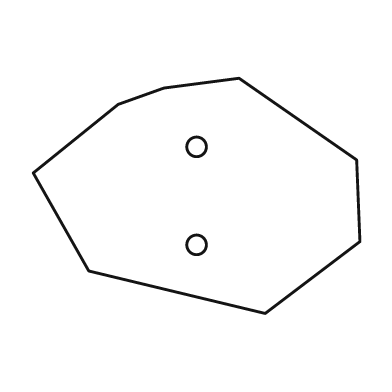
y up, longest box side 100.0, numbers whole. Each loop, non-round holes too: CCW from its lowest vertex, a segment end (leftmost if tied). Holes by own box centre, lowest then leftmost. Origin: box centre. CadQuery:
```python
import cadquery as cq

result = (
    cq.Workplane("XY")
    .moveTo(21.0, -36.0)
    .lineTo(50.0, -14.0)
    .lineTo(49.0, 11.0)
    .lineTo(13.0, 36.0)
    .lineTo(-10.0, 33.0)
    .lineTo(-24.0, 28.0)
    .lineTo(-50.0, 7.0)
    .lineTo(-33.0, -23.0)
    .close()
    .moveTo(0.0, -15.0)
    .circle(3.0)
    .moveTo(0.0, 15.0)
    .circle(3.0)
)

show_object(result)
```